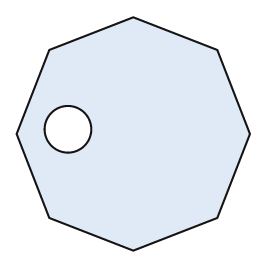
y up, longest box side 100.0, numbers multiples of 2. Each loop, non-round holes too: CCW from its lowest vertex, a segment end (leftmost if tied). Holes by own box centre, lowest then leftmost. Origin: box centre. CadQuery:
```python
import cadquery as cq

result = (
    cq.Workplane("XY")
    .moveTo(0.0, -50.0)
    .lineTo(36.0, -36.0)
    .lineTo(50.0, 0.0)
    .lineTo(36.0, 36.0)
    .lineTo(0.0, 50.0)
    .lineTo(-36.0, 36.0)
    .lineTo(-50.0, 0.0)
    .lineTo(-36.0, -36.0)
    .close()
    .moveTo(-28.0, 2.0)
    .circle(10.0)
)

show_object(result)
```